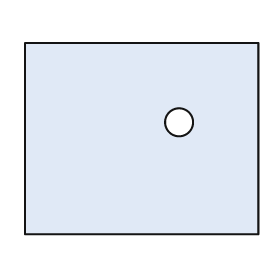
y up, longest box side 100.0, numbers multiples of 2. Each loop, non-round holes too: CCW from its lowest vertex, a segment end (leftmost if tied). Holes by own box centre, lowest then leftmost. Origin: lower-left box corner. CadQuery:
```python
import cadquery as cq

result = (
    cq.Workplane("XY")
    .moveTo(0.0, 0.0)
    .lineTo(100.0, 0.0)
    .lineTo(100.0, 82.0)
    .lineTo(0.0, 82.0)
    .close()
    .moveTo(66.0, 48.0)
    .circle(6.0)
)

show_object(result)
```